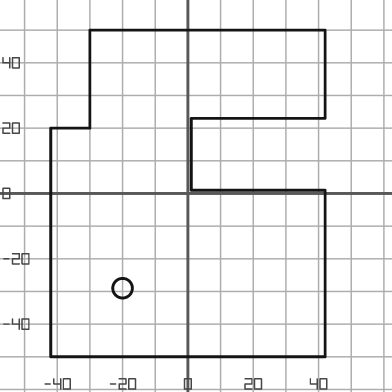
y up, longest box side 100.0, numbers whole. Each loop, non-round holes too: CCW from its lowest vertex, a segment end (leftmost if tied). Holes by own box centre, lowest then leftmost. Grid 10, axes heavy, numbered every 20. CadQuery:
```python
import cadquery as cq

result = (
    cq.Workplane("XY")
    .moveTo(-42.0, -50.0)
    .lineTo(42.0, -50.0)
    .lineTo(42.0, 1.0)
    .lineTo(1.0, 1.0)
    .lineTo(1.0, 23.0)
    .lineTo(42.0, 23.0)
    .lineTo(42.0, 50.0)
    .lineTo(-30.0, 50.0)
    .lineTo(-30.0, 20.0)
    .lineTo(-42.0, 20.0)
    .close()
    .moveTo(-20.0, -29.0)
    .circle(3.0)
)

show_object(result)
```